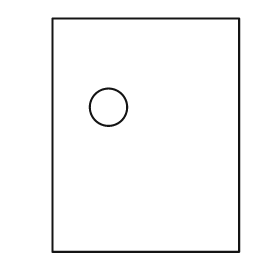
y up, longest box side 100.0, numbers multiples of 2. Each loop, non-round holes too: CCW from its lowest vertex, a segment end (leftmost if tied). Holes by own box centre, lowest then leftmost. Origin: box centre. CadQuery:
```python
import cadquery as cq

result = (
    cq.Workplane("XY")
    .moveTo(-40.0, -50.0)
    .lineTo(40.0, -50.0)
    .lineTo(40.0, 50.0)
    .lineTo(-40.0, 50.0)
    .close()
    .moveTo(-16.0, 12.0)
    .circle(8.0)
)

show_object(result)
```